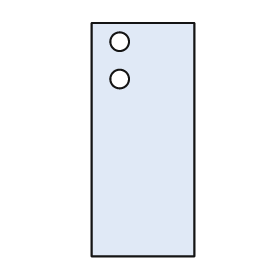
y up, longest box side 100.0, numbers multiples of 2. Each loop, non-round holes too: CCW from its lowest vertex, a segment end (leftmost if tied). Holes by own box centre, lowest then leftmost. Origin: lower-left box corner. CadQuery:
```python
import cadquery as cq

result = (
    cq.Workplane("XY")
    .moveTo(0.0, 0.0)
    .lineTo(44.0, 0.0)
    .lineTo(44.0, 100.0)
    .lineTo(0.0, 100.0)
    .close()
    .moveTo(12.0, 76.0)
    .circle(4.0)
    .moveTo(12.0, 92.0)
    .circle(4.0)
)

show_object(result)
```